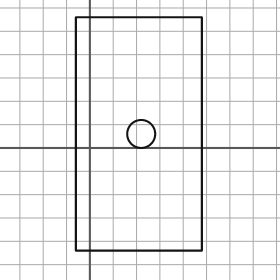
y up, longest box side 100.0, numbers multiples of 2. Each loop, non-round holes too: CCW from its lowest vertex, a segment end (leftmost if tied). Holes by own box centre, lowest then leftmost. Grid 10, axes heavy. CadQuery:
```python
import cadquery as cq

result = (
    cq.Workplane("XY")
    .moveTo(-6.0, -44.0)
    .lineTo(48.0, -44.0)
    .lineTo(48.0, 56.0)
    .lineTo(-6.0, 56.0)
    .close()
    .moveTo(22.0, 6.0)
    .circle(6.0)
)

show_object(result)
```